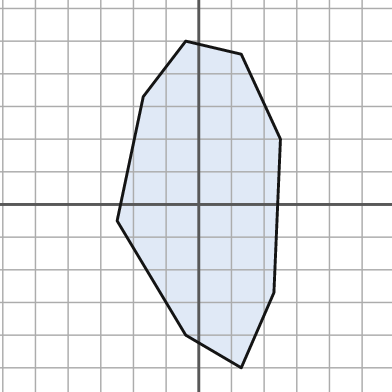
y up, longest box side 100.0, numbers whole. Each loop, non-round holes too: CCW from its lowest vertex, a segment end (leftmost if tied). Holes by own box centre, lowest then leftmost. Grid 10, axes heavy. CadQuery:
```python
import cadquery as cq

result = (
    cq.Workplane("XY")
    .moveTo(13.0, -50.0)
    .lineTo(23.0, -27.0)
    .lineTo(25.0, 20.0)
    .lineTo(13.0, 46.0)
    .lineTo(-4.0, 50.0)
    .lineTo(-17.0, 33.0)
    .lineTo(-25.0, -5.0)
    .lineTo(-4.0, -40.0)
    .close()
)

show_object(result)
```